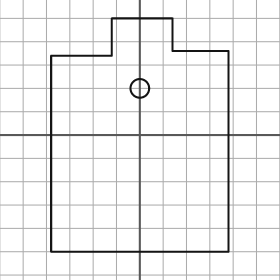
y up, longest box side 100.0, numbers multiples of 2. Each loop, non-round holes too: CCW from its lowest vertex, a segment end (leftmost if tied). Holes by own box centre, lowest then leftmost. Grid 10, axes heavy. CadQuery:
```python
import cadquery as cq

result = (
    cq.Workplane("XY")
    .moveTo(-38.0, -50.0)
    .lineTo(38.0, -50.0)
    .lineTo(38.0, 36.0)
    .lineTo(14.0, 36.0)
    .lineTo(14.0, 50.0)
    .lineTo(-12.0, 50.0)
    .lineTo(-12.0, 34.0)
    .lineTo(-38.0, 34.0)
    .close()
    .moveTo(0.0, 20.0)
    .circle(4.0)
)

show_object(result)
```